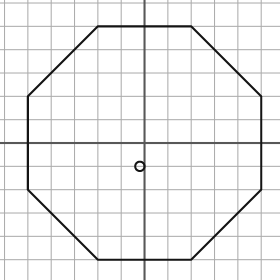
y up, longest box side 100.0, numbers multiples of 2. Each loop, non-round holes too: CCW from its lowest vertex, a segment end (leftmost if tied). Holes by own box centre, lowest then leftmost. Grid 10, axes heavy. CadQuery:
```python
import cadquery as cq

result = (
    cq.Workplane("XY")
    .moveTo(-20.0, -50.0)
    .lineTo(20.0, -50.0)
    .lineTo(50.0, -20.0)
    .lineTo(50.0, 20.0)
    .lineTo(20.0, 50.0)
    .lineTo(-20.0, 50.0)
    .lineTo(-50.0, 20.0)
    .lineTo(-50.0, -20.0)
    .close()
    .moveTo(-2.0, -10.0)
    .circle(2.0)
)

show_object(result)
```